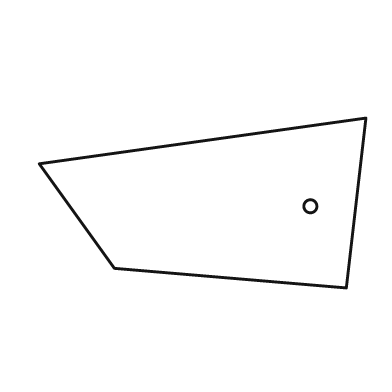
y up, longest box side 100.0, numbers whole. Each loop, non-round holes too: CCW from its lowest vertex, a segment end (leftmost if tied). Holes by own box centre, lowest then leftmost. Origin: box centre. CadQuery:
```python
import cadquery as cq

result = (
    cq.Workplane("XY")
    .moveTo(44.0, -26.0)
    .lineTo(50.0, 26.0)
    .lineTo(-50.0, 12.0)
    .lineTo(-27.0, -20.0)
    .close()
    .moveTo(33.0, -1.0)
    .circle(2.0)
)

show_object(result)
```